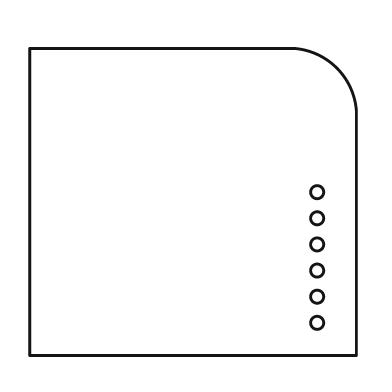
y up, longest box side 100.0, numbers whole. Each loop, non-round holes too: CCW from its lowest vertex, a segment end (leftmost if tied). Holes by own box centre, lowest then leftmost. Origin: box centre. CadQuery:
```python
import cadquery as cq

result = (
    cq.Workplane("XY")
    .moveTo(-50.0, -47.0)
    .lineTo(50.0, -47.0)
    .lineTo(50.0, 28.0)
    .threePointArc((44.0, 41.0), (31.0, 47.0))
    .lineTo(-50.0, 47.0)
    .close()
    .moveTo(38.0, -37.0)
    .circle(2.0)
    .moveTo(38.0, -29.0)
    .circle(2.0)
    .moveTo(38.0, -21.0)
    .circle(2.0)
    .moveTo(38.0, -13.0)
    .circle(2.0)
    .moveTo(38.0, -5.0)
    .circle(2.0)
    .moveTo(38.0, 3.0)
    .circle(2.0)
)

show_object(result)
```